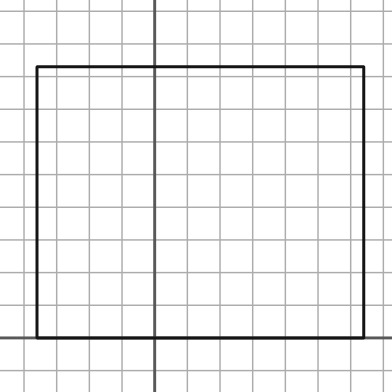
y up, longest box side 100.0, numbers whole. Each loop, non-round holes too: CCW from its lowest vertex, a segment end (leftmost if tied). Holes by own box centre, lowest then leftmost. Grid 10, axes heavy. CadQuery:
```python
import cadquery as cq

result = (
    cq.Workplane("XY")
    .moveTo(-36.0, 0.0)
    .lineTo(64.0, 0.0)
    .lineTo(64.0, 83.0)
    .lineTo(-36.0, 83.0)
    .close()
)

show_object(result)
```